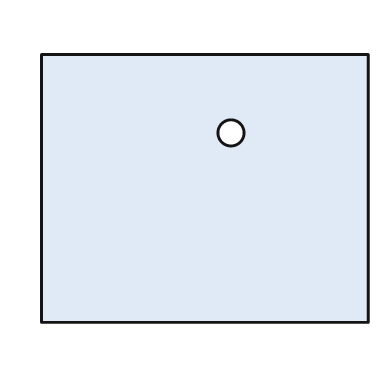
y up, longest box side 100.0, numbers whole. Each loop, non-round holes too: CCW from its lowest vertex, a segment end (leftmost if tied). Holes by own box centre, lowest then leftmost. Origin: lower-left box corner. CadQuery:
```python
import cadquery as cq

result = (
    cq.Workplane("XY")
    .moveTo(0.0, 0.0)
    .lineTo(100.0, 0.0)
    .lineTo(100.0, 82.0)
    .lineTo(0.0, 82.0)
    .close()
    .moveTo(58.0, 58.0)
    .circle(4.0)
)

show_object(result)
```